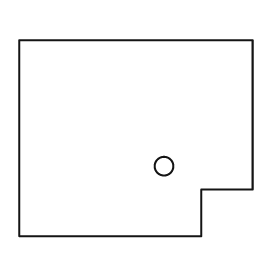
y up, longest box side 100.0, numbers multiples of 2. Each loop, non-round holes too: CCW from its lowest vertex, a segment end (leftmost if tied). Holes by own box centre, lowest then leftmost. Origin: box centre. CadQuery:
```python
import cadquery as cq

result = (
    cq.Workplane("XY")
    .moveTo(-50.0, -42.0)
    .lineTo(28.0, -42.0)
    .lineTo(28.0, -22.0)
    .lineTo(50.0, -22.0)
    .lineTo(50.0, 42.0)
    .lineTo(-50.0, 42.0)
    .close()
    .moveTo(12.0, -12.0)
    .circle(4.0)
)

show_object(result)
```